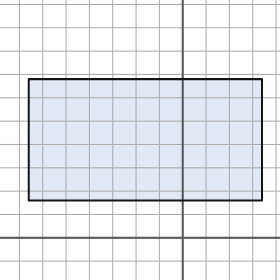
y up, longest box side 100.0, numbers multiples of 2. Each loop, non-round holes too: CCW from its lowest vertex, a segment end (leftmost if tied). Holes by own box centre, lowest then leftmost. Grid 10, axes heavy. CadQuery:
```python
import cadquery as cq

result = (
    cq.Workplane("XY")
    .moveTo(-66.0, 16.0)
    .lineTo(34.0, 16.0)
    .lineTo(34.0, 68.0)
    .lineTo(-66.0, 68.0)
    .close()
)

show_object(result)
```